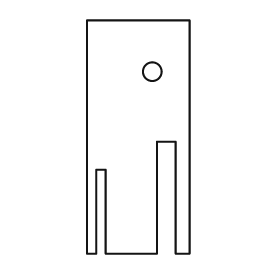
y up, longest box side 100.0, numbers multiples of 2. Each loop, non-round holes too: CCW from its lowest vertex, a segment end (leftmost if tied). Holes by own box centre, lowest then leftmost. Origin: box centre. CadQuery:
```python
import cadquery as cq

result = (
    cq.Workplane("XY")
    .moveTo(-22.0, -50.0)
    .lineTo(-18.0, -50.0)
    .lineTo(-18.0, -14.0)
    .lineTo(-14.0, -14.0)
    .lineTo(-14.0, -50.0)
    .lineTo(8.0, -50.0)
    .lineTo(8.0, -2.0)
    .lineTo(16.0, -2.0)
    .lineTo(16.0, -50.0)
    .lineTo(22.0, -50.0)
    .lineTo(22.0, 50.0)
    .lineTo(-22.0, 50.0)
    .close()
    .moveTo(6.0, 28.0)
    .circle(4.0)
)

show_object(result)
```